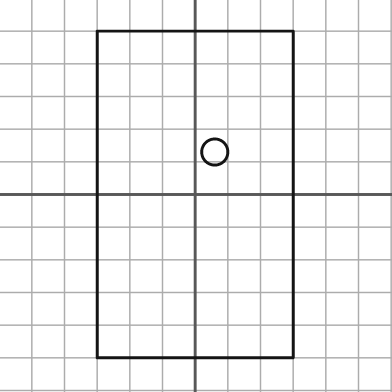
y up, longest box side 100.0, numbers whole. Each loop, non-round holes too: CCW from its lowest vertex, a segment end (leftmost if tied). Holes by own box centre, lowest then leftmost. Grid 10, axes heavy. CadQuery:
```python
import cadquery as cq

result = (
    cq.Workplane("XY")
    .moveTo(-30.0, -50.0)
    .lineTo(30.0, -50.0)
    .lineTo(30.0, 50.0)
    .lineTo(-30.0, 50.0)
    .close()
    .moveTo(6.0, 13.0)
    .circle(4.0)
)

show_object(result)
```